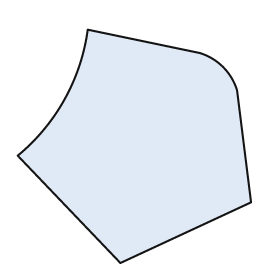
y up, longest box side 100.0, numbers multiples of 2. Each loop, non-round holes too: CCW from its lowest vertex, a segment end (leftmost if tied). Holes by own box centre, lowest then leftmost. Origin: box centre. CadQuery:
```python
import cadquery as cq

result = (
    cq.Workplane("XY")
    .moveTo(-6.0, -50.0)
    .lineTo(50.0, -24.0)
    .lineTo(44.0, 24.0)
    .threePointArc((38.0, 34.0), (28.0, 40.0))
    .lineTo(-20.0, 50.0)
    .threePointArc((-30.0, 20.0), (-50.0, -4.0))
    .close()
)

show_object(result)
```